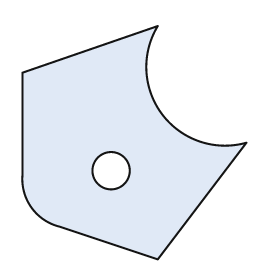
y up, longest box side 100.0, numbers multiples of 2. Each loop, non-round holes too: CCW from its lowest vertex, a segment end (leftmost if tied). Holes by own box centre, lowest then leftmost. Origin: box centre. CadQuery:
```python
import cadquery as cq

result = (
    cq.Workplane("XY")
    .moveTo(10.0, -50.0)
    .lineTo(48.0, 0.0)
    .threePointArc((12.0, 12.0), (10.0, 50.0))
    .lineTo(-48.0, 30.0)
    .lineTo(-48.0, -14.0)
    .threePointArc((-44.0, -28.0), (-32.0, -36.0))
    .close()
    .moveTo(-10.0, -12.0)
    .circle(8.0)
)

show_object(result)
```